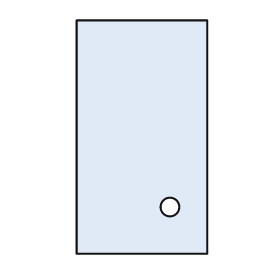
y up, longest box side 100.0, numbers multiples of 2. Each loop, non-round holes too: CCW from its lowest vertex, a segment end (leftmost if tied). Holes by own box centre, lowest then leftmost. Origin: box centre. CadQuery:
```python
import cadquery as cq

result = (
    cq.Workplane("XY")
    .moveTo(-28.0, -50.0)
    .lineTo(28.0, -50.0)
    .lineTo(28.0, 50.0)
    .lineTo(-28.0, 50.0)
    .close()
    .moveTo(12.0, -30.0)
    .circle(4.0)
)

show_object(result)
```